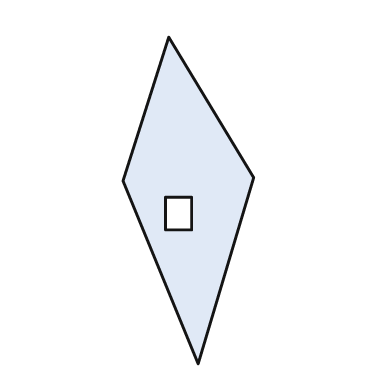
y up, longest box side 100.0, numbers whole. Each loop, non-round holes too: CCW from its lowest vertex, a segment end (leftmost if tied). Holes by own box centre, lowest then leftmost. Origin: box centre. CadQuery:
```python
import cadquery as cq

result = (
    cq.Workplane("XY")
    .moveTo(3.0, -50.0)
    .lineTo(20.0, 7.0)
    .lineTo(-6.0, 50.0)
    .lineTo(-20.0, 6.0)
    .close()
    .moveTo(-7.0, -9.0)
    .lineTo(1.0, -9.0)
    .lineTo(1.0, 1.0)
    .lineTo(-7.0, 1.0)
    .close()
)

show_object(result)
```